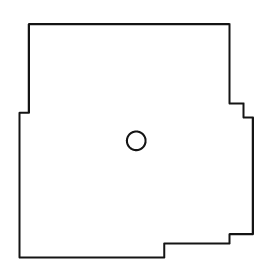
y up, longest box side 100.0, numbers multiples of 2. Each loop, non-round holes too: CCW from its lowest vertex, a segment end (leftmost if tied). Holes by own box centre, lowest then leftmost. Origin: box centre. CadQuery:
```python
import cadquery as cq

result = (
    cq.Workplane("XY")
    .moveTo(-50.0, -50.0)
    .lineTo(12.0, -50.0)
    .lineTo(12.0, -44.0)
    .lineTo(40.0, -44.0)
    .lineTo(40.0, -40.0)
    .lineTo(50.0, -40.0)
    .lineTo(50.0, 10.0)
    .lineTo(46.0, 10.0)
    .lineTo(46.0, 16.0)
    .lineTo(40.0, 16.0)
    .lineTo(40.0, 50.0)
    .lineTo(-46.0, 50.0)
    .lineTo(-46.0, 12.0)
    .lineTo(-50.0, 12.0)
    .close()
    .moveTo(0.0, 0.0)
    .circle(4.0)
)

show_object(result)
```